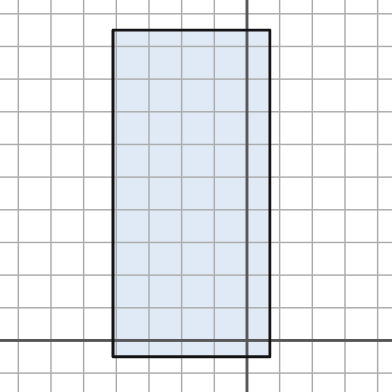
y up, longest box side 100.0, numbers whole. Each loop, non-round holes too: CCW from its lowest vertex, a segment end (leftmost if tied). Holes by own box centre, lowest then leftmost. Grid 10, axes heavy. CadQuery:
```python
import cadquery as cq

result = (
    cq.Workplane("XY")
    .moveTo(-41.0, -5.0)
    .lineTo(7.0, -5.0)
    .lineTo(7.0, 95.0)
    .lineTo(-41.0, 95.0)
    .close()
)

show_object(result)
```